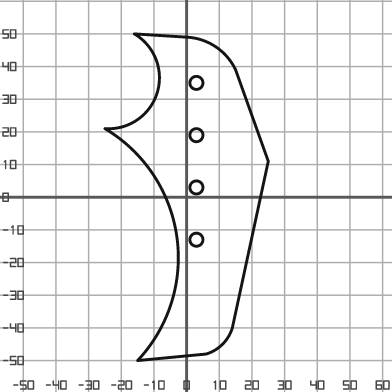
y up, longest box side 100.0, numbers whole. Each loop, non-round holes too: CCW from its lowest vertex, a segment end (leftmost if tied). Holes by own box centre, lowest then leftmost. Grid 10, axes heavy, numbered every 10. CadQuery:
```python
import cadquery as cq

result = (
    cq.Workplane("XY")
    .moveTo(-15.0, -50.0)
    .lineTo(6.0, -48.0)
    .threePointArc((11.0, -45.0), (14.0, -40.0))
    .lineTo(25.0, 11.0)
    .lineTo(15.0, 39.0)
    .threePointArc((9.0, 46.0), (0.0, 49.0))
    .lineTo(-16.0, 50.0)
    .threePointArc((-9.0, 32.0), (-25.0, 21.0))
    .threePointArc((-3.0, -12.0), (-15.0, -50.0))
    .close()
    .moveTo(3.0, -13.0)
    .circle(2.0)
    .moveTo(3.0, 3.0)
    .circle(2.0)
    .moveTo(3.0, 19.0)
    .circle(2.0)
    .moveTo(3.0, 35.0)
    .circle(2.0)
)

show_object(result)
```